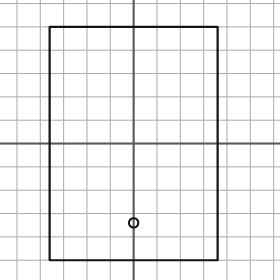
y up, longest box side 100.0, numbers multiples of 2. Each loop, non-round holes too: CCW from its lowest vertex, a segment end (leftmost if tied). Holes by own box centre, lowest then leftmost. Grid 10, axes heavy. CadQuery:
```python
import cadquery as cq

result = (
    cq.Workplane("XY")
    .moveTo(-36.0, -50.0)
    .lineTo(36.0, -50.0)
    .lineTo(36.0, 50.0)
    .lineTo(-36.0, 50.0)
    .close()
    .moveTo(0.0, -34.0)
    .circle(2.0)
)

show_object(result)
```